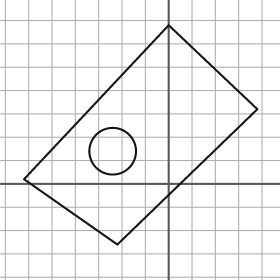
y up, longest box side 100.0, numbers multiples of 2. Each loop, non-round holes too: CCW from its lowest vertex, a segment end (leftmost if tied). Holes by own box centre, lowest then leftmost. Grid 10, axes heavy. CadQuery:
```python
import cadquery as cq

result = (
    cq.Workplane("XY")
    .moveTo(-22.0, -26.0)
    .lineTo(38.0, 32.0)
    .lineTo(0.0, 68.0)
    .lineTo(-62.0, 2.0)
    .close()
    .moveTo(-24.0, 14.0)
    .circle(10.0)
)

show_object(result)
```